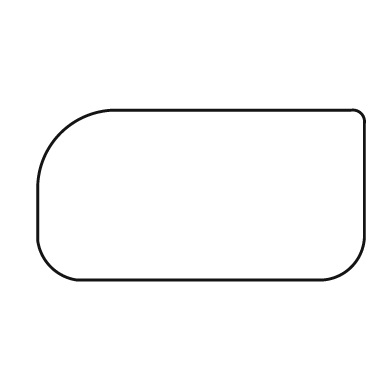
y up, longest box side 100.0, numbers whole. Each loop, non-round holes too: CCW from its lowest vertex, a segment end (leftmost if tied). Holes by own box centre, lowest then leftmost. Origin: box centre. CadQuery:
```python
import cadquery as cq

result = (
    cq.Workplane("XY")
    .moveTo(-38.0, -26.0)
    .lineTo(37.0, -26.0)
    .threePointArc((46.0, -22.0), (50.0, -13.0))
    .lineTo(50.0, 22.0)
    .threePointArc((49.0, 25.0), (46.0, 26.0))
    .lineTo(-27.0, 26.0)
    .threePointArc((-43.0, 19.0), (-50.0, 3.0))
    .lineTo(-50.0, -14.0)
    .threePointArc((-46.0, -22.0), (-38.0, -26.0))
    .close()
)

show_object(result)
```